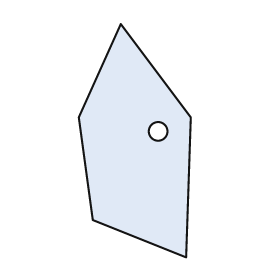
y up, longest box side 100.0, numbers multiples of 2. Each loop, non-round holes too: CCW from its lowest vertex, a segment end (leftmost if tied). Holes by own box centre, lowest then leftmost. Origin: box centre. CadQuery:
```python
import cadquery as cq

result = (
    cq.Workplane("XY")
    .moveTo(22.0, -50.0)
    .lineTo(24.0, 10.0)
    .lineTo(-6.0, 50.0)
    .lineTo(-24.0, 10.0)
    .lineTo(-18.0, -34.0)
    .close()
    .moveTo(10.0, 4.0)
    .circle(4.0)
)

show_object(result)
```